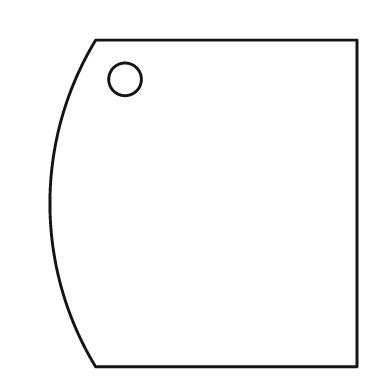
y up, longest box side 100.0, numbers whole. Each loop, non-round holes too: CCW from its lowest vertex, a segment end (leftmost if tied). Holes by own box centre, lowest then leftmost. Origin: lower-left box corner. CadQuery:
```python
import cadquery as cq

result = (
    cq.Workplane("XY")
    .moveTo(14.0, 0.0)
    .lineTo(94.0, 0.0)
    .lineTo(94.0, 100.0)
    .lineTo(14.0, 100.0)
    .threePointArc((0.0, 50.0), (14.0, 0.0))
    .close()
    .moveTo(23.0, 88.0)
    .circle(5.0)
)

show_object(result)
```